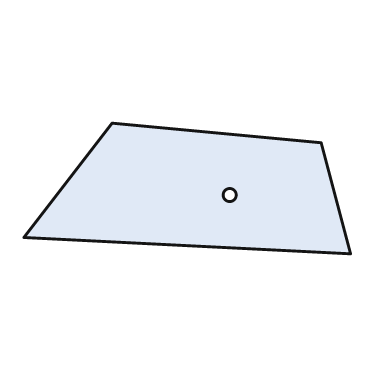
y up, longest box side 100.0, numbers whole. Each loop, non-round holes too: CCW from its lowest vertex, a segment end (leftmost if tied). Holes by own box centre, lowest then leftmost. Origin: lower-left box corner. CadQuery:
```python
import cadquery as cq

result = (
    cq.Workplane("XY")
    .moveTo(100.0, 0.0)
    .lineTo(91.0, 34.0)
    .lineTo(27.0, 40.0)
    .lineTo(0.0, 5.0)
    .close()
    .moveTo(63.0, 18.0)
    .circle(2.0)
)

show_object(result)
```